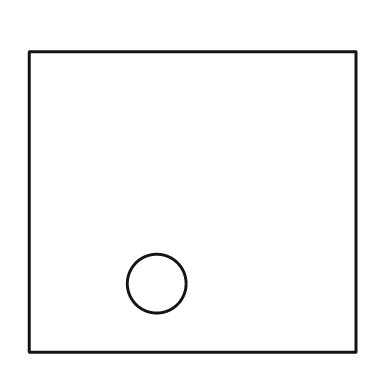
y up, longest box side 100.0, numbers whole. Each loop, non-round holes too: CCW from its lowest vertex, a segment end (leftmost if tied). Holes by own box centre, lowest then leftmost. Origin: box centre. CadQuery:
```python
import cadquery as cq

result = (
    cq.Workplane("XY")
    .moveTo(-50.0, -46.0)
    .lineTo(50.0, -46.0)
    .lineTo(50.0, 46.0)
    .lineTo(-50.0, 46.0)
    .close()
    .moveTo(-11.0, -25.0)
    .circle(9.0)
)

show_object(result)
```